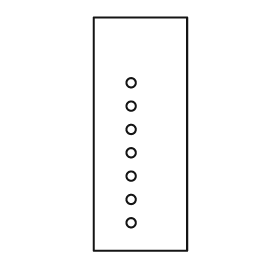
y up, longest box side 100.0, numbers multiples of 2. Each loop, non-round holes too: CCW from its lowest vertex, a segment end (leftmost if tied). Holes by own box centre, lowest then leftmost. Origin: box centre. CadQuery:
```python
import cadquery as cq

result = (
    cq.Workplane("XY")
    .moveTo(-20.0, -50.0)
    .lineTo(20.0, -50.0)
    .lineTo(20.0, 50.0)
    .lineTo(-20.0, 50.0)
    .close()
    .moveTo(-4.0, -38.0)
    .circle(2.0)
    .moveTo(-4.0, -28.0)
    .circle(2.0)
    .moveTo(-4.0, -18.0)
    .circle(2.0)
    .moveTo(-4.0, -8.0)
    .circle(2.0)
    .moveTo(-4.0, 2.0)
    .circle(2.0)
    .moveTo(-4.0, 12.0)
    .circle(2.0)
    .moveTo(-4.0, 22.0)
    .circle(2.0)
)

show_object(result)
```